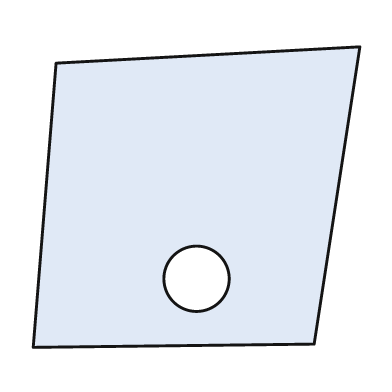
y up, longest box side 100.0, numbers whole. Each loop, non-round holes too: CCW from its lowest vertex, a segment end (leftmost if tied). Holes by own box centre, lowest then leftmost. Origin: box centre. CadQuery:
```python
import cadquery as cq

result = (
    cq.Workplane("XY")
    .moveTo(-50.0, -46.0)
    .lineTo(36.0, -45.0)
    .lineTo(50.0, 46.0)
    .lineTo(-43.0, 41.0)
    .close()
    .moveTo(0.0, -25.0)
    .circle(10.0)
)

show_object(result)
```